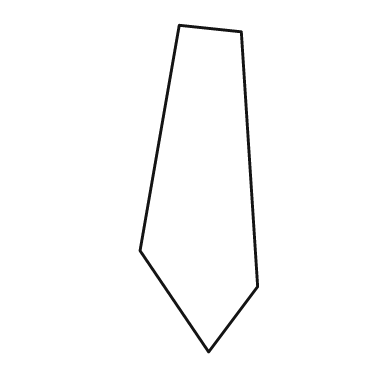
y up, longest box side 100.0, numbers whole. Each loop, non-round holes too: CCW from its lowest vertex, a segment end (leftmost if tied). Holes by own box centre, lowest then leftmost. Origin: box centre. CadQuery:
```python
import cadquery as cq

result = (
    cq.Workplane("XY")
    .moveTo(3.0, -50.0)
    .lineTo(18.0, -30.0)
    .lineTo(13.0, 48.0)
    .lineTo(-6.0, 50.0)
    .lineTo(-18.0, -19.0)
    .close()
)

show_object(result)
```